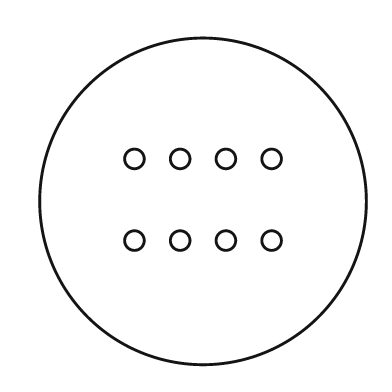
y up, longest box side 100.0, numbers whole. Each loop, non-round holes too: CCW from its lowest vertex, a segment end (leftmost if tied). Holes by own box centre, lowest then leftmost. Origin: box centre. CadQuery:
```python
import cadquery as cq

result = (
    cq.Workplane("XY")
    .moveTo(0.0, 0.0)
    .circle(50.0)
    .moveTo(-21.0, -12.0)
    .circle(3.0)
    .moveTo(-7.0, -12.0)
    .circle(3.0)
    .moveTo(7.0, -12.0)
    .circle(3.0)
    .moveTo(21.0, -12.0)
    .circle(3.0)
    .moveTo(-21.0, 13.0)
    .circle(3.0)
    .moveTo(-7.0, 13.0)
    .circle(3.0)
    .moveTo(7.0, 13.0)
    .circle(3.0)
    .moveTo(21.0, 13.0)
    .circle(3.0)
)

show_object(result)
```